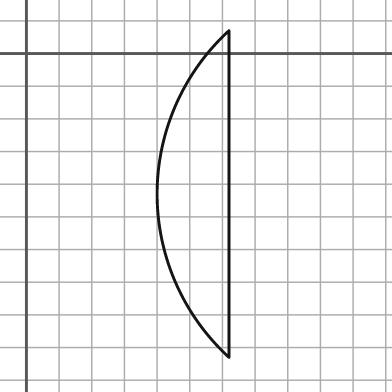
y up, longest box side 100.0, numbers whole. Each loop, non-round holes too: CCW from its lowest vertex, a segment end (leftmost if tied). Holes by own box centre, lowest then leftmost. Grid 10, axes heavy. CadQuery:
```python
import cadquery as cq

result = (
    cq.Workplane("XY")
    .moveTo(62.0, -93.0)
    .lineTo(62.0, 7.0)
    .threePointArc((40.0, -43.0), (62.0, -93.0))
    .close()
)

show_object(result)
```